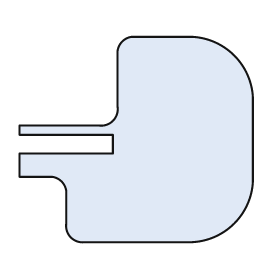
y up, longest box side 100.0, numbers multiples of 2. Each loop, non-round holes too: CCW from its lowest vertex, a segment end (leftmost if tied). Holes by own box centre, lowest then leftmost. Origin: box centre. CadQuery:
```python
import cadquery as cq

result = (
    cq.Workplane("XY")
    .moveTo(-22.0, -44.0)
    .lineTo(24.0, -44.0)
    .threePointArc((42.0, -36.0), (50.0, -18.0))
    .lineTo(50.0, 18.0)
    .threePointArc((42.0, 36.0), (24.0, 44.0))
    .lineTo(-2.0, 44.0)
    .threePointArc((-6.0, 42.0), (-8.0, 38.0))
    .lineTo(-8.0, 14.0)
    .threePointArc((-10.0, 8.0), (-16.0, 6.0))
    .lineTo(-50.0, 6.0)
    .lineTo(-50.0, 2.0)
    .lineTo(-10.0, 2.0)
    .lineTo(-10.0, -6.0)
    .lineTo(-50.0, -6.0)
    .lineTo(-50.0, -16.0)
    .lineTo(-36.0, -16.0)
    .threePointArc((-32.0, -18.0), (-30.0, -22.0))
    .lineTo(-30.0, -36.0)
    .threePointArc((-28.0, -42.0), (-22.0, -44.0))
    .close()
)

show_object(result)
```